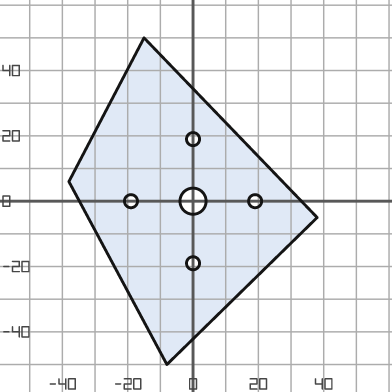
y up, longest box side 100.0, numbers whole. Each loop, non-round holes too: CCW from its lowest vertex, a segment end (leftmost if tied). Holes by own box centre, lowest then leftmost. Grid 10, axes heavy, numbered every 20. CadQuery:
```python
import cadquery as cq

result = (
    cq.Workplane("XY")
    .moveTo(-8.0, -50.0)
    .lineTo(38.0, -5.0)
    .lineTo(-15.0, 50.0)
    .lineTo(-38.0, 6.0)
    .close()
    .moveTo(0.0, -19.0)
    .circle(2.0)
    .moveTo(-19.0, 0.0)
    .circle(2.0)
    .moveTo(0.0, 0.0)
    .circle(4.0)
    .moveTo(19.0, 0.0)
    .circle(2.0)
    .moveTo(0.0, 19.0)
    .circle(2.0)
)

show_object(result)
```